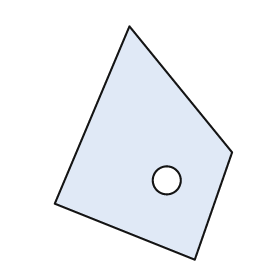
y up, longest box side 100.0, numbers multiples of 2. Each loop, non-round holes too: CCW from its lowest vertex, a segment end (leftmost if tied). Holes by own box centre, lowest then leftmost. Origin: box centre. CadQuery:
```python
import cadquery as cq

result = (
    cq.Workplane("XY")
    .moveTo(22.0, -50.0)
    .lineTo(38.0, -4.0)
    .lineTo(-6.0, 50.0)
    .lineTo(-38.0, -26.0)
    .close()
    .moveTo(10.0, -16.0)
    .circle(6.0)
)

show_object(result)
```